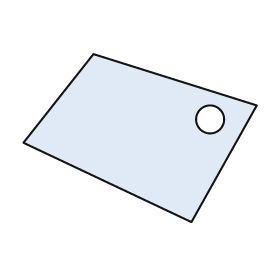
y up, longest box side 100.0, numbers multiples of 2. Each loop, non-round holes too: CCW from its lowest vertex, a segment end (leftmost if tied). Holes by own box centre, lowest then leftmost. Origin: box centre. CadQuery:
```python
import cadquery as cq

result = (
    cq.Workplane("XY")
    .moveTo(22.0, -36.0)
    .lineTo(50.0, 14.0)
    .lineTo(-20.0, 36.0)
    .lineTo(-50.0, -2.0)
    .close()
    .moveTo(30.0, 8.0)
    .circle(6.0)
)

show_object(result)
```